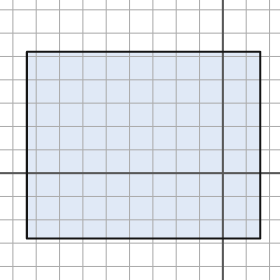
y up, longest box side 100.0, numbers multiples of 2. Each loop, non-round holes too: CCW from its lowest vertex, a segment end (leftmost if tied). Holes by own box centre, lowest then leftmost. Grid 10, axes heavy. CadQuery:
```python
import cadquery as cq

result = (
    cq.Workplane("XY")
    .moveTo(-84.0, -28.0)
    .lineTo(16.0, -28.0)
    .lineTo(16.0, 52.0)
    .lineTo(-84.0, 52.0)
    .close()
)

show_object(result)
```